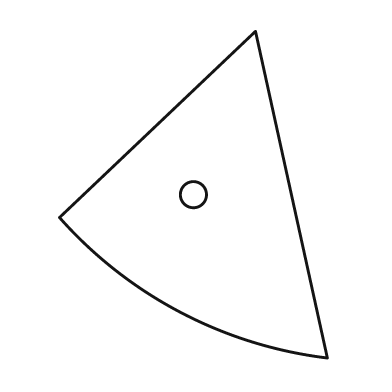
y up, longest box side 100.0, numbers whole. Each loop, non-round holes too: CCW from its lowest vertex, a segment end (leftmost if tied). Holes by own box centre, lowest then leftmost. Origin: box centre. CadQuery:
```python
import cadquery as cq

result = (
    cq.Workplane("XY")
    .moveTo(41.0, -50.0)
    .lineTo(19.0, 50.0)
    .lineTo(-41.0, -7.0)
    .threePointArc((-4.0, -36.0), (41.0, -50.0))
    .close()
    .moveTo(0.0, 0.0)
    .circle(4.0)
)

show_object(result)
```